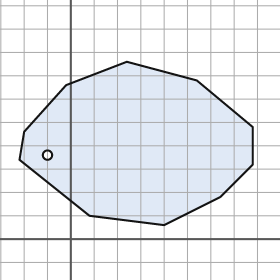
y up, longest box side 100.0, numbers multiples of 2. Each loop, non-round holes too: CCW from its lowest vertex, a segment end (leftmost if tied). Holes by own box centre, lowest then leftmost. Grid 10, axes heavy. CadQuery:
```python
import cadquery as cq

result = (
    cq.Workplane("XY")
    .moveTo(40.0, 6.0)
    .lineTo(64.0, 18.0)
    .lineTo(78.0, 32.0)
    .lineTo(78.0, 48.0)
    .lineTo(54.0, 68.0)
    .lineTo(24.0, 76.0)
    .lineTo(-2.0, 66.0)
    .lineTo(-20.0, 46.0)
    .lineTo(-22.0, 34.0)
    .lineTo(8.0, 10.0)
    .close()
    .moveTo(-10.0, 36.0)
    .circle(2.0)
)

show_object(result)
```